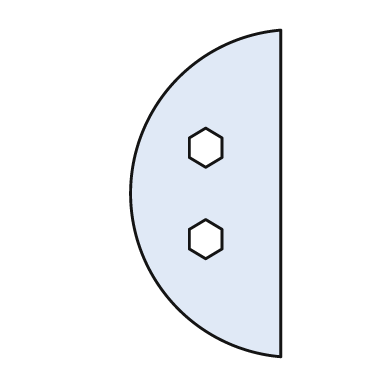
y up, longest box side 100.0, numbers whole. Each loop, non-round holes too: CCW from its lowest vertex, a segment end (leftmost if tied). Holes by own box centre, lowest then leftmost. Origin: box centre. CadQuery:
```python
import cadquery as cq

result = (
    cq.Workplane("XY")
    .moveTo(23.0, -50.0)
    .lineTo(23.0, 50.0)
    .threePointArc((-23.0, 0.0), (23.0, -50.0))
    .close()
    .moveTo(0.0, -20.0)
    .lineTo(5.0, -17.0)
    .lineTo(5.0, -11.0)
    .lineTo(0.0, -8.0)
    .lineTo(-5.0, -11.0)
    .lineTo(-5.0, -17.0)
    .close()
    .moveTo(0.0, 8.0)
    .lineTo(5.0, 11.0)
    .lineTo(5.0, 17.0)
    .lineTo(0.0, 20.0)
    .lineTo(-5.0, 17.0)
    .lineTo(-5.0, 11.0)
    .close()
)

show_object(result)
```